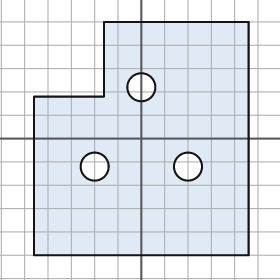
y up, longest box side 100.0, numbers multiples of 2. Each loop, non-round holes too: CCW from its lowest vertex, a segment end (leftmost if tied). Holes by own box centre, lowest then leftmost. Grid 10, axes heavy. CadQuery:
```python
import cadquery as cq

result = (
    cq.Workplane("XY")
    .moveTo(-46.0, -50.0)
    .lineTo(46.0, -50.0)
    .lineTo(46.0, 50.0)
    .lineTo(-16.0, 50.0)
    .lineTo(-16.0, 18.0)
    .lineTo(-46.0, 18.0)
    .close()
    .moveTo(-20.0, -12.0)
    .circle(6.0)
    .moveTo(20.0, -12.0)
    .circle(6.0)
    .moveTo(0.0, 22.0)
    .circle(6.0)
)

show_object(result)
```